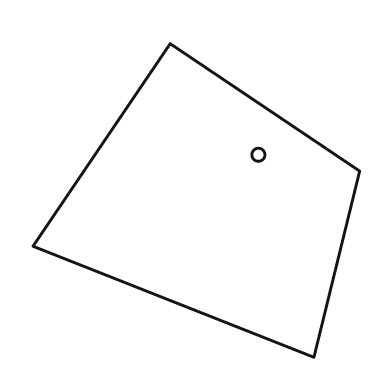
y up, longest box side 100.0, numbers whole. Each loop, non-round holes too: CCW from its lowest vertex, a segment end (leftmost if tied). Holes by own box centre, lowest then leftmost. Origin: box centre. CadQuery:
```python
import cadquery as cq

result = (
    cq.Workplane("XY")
    .moveTo(36.0, -48.0)
    .lineTo(50.0, 9.0)
    .lineTo(-8.0, 48.0)
    .lineTo(-50.0, -14.0)
    .close()
    .moveTo(19.0, 14.0)
    .circle(2.0)
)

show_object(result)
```